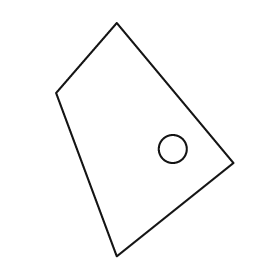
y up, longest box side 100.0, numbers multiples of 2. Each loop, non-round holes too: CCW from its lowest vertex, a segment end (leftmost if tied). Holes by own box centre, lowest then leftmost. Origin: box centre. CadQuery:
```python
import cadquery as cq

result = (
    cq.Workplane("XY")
    .moveTo(-12.0, -50.0)
    .lineTo(38.0, -10.0)
    .lineTo(-12.0, 50.0)
    .lineTo(-38.0, 20.0)
    .close()
    .moveTo(12.0, -4.0)
    .circle(6.0)
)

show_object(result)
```